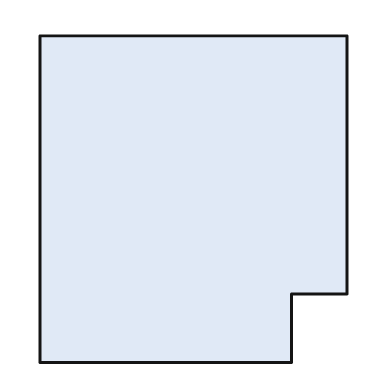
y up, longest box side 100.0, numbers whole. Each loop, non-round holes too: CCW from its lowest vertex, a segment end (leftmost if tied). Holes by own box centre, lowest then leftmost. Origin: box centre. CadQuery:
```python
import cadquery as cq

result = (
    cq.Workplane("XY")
    .moveTo(-47.0, -50.0)
    .lineTo(30.0, -50.0)
    .lineTo(30.0, -29.0)
    .lineTo(47.0, -29.0)
    .lineTo(47.0, 50.0)
    .lineTo(-47.0, 50.0)
    .close()
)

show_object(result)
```